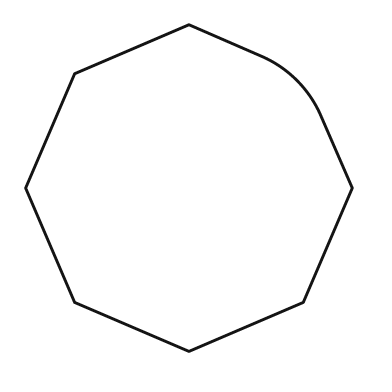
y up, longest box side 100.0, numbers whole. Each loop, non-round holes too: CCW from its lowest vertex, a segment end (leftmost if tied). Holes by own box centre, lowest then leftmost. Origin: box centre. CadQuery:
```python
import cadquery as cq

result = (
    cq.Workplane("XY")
    .moveTo(0.0, -50.0)
    .lineTo(35.0, -35.0)
    .lineTo(50.0, 0.0)
    .lineTo(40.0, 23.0)
    .threePointArc((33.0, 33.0), (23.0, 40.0))
    .lineTo(0.0, 50.0)
    .lineTo(-35.0, 35.0)
    .lineTo(-50.0, 0.0)
    .lineTo(-35.0, -35.0)
    .close()
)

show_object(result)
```